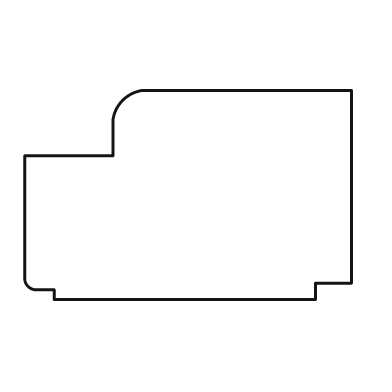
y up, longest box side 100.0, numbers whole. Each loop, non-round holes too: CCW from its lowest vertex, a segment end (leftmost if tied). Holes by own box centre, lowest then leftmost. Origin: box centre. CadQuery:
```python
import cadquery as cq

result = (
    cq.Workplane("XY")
    .moveTo(-41.0, -32.0)
    .lineTo(39.0, -32.0)
    .lineTo(39.0, -27.0)
    .lineTo(50.0, -27.0)
    .lineTo(50.0, 32.0)
    .lineTo(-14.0, 32.0)
    .threePointArc((-20.0, 29.0), (-23.0, 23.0))
    .lineTo(-23.0, 12.0)
    .lineTo(-50.0, 12.0)
    .lineTo(-50.0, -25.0)
    .threePointArc((-49.0, -28.0), (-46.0, -29.0))
    .lineTo(-41.0, -29.0)
    .close()
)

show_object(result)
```